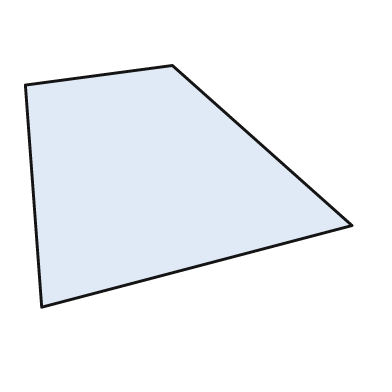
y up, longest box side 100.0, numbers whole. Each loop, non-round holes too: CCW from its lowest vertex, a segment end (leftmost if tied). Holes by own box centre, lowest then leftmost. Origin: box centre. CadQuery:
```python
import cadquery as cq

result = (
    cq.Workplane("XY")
    .moveTo(-45.0, -37.0)
    .lineTo(50.0, -12.0)
    .lineTo(-5.0, 37.0)
    .lineTo(-50.0, 31.0)
    .close()
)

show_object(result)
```